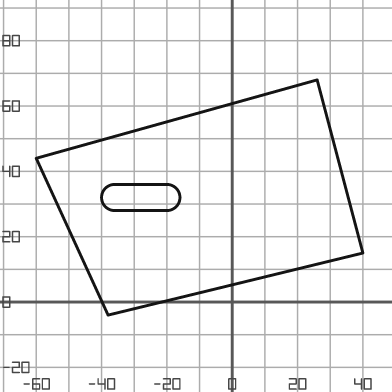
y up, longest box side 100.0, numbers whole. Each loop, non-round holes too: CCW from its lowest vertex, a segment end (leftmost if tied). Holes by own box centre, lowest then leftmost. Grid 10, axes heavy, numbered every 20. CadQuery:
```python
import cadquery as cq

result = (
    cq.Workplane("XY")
    .moveTo(-38.0, -4.0)
    .lineTo(40.0, 15.0)
    .lineTo(26.0, 68.0)
    .lineTo(-60.0, 44.0)
    .close()
    .moveTo(-36.0, 28.0)
    .lineTo(-20.0, 28.0)
    .threePointArc((-16.0, 32.0), (-20.0, 36.0))
    .lineTo(-36.0, 36.0)
    .threePointArc((-40.0, 32.0), (-36.0, 28.0))
    .close()
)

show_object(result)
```